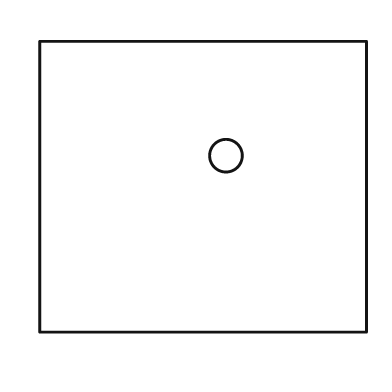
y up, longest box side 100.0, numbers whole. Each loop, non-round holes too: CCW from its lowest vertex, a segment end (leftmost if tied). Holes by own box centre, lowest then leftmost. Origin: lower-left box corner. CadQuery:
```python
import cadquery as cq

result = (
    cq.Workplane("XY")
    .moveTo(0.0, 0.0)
    .lineTo(100.0, 0.0)
    .lineTo(100.0, 89.0)
    .lineTo(0.0, 89.0)
    .close()
    .moveTo(57.0, 54.0)
    .circle(5.0)
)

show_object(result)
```